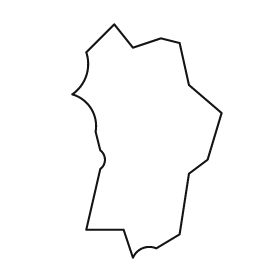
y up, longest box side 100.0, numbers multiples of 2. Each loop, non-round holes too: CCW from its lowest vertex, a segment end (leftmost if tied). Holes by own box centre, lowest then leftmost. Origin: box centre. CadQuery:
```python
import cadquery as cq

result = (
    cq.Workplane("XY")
    .moveTo(-6.0, -50.0)
    .threePointArc((-2.0, -46.0), (4.0, -46.0))
    .lineTo(14.0, -40.0)
    .lineTo(18.0, -14.0)
    .lineTo(26.0, -8.0)
    .lineTo(32.0, 12.0)
    .lineTo(18.0, 24.0)
    .lineTo(14.0, 42.0)
    .lineTo(6.0, 44.0)
    .lineTo(-6.0, 40.0)
    .lineTo(-14.0, 50.0)
    .lineTo(-26.0, 38.0)
    .threePointArc((-26.0, 28.0), (-32.0, 20.0))
    .threePointArc((-24.0, 14.0), (-22.0, 4.0))
    .lineTo(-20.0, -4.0)
    .threePointArc((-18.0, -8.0), (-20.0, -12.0))
    .lineTo(-26.0, -38.0)
    .lineTo(-10.0, -38.0)
    .close()
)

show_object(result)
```